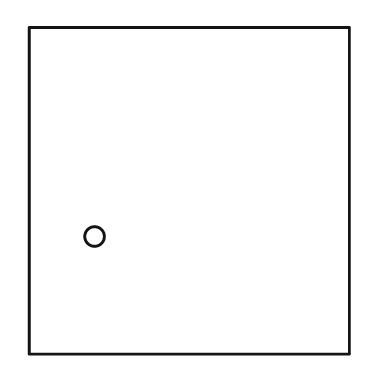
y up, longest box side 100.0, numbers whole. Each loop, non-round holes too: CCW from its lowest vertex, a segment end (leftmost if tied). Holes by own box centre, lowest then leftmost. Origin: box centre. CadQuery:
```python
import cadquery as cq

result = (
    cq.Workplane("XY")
    .moveTo(-49.0, -50.0)
    .lineTo(49.0, -50.0)
    .lineTo(49.0, 50.0)
    .lineTo(-49.0, 50.0)
    .close()
    .moveTo(-29.0, -14.0)
    .circle(3.0)
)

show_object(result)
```